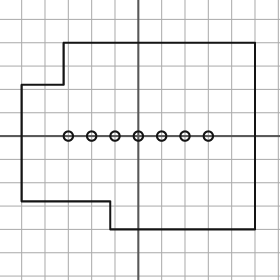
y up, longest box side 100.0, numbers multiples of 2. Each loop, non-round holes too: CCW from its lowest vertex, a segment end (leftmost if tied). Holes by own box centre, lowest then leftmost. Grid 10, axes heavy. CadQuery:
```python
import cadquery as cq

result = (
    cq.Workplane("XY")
    .moveTo(-12.0, -40.0)
    .lineTo(50.0, -40.0)
    .lineTo(50.0, 40.0)
    .lineTo(-32.0, 40.0)
    .lineTo(-32.0, 22.0)
    .lineTo(-50.0, 22.0)
    .lineTo(-50.0, -28.0)
    .lineTo(-12.0, -28.0)
    .close()
    .moveTo(-30.0, 0.0)
    .circle(2.0)
    .moveTo(-20.0, 0.0)
    .circle(2.0)
    .moveTo(-10.0, 0.0)
    .circle(2.0)
    .moveTo(0.0, 0.0)
    .circle(2.0)
    .moveTo(10.0, 0.0)
    .circle(2.0)
    .moveTo(20.0, 0.0)
    .circle(2.0)
    .moveTo(30.0, 0.0)
    .circle(2.0)
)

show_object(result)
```